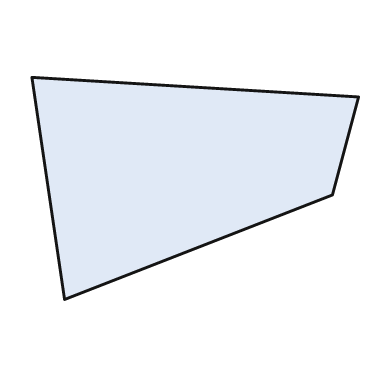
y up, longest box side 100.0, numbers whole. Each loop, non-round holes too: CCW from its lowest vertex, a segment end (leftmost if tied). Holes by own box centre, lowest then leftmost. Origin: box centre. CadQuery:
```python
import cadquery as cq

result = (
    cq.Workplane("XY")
    .moveTo(-40.0, -34.0)
    .lineTo(42.0, -2.0)
    .lineTo(50.0, 28.0)
    .lineTo(-50.0, 34.0)
    .close()
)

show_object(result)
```